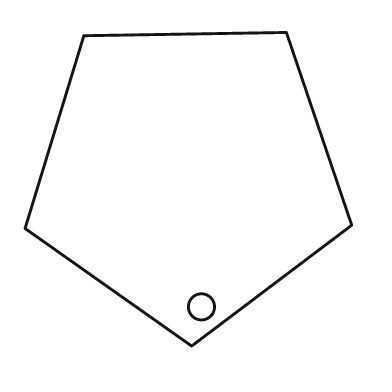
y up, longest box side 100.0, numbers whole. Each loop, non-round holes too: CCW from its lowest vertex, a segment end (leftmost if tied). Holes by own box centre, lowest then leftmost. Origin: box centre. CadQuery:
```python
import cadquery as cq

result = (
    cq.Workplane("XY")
    .moveTo(1.0, -48.0)
    .lineTo(50.0, -11.0)
    .lineTo(30.0, 48.0)
    .lineTo(-32.0, 47.0)
    .lineTo(-50.0, -12.0)
    .close()
    .moveTo(4.0, -36.0)
    .circle(4.0)
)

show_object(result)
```